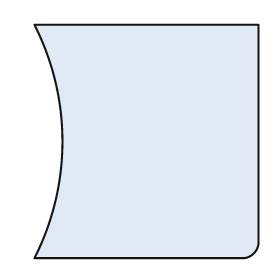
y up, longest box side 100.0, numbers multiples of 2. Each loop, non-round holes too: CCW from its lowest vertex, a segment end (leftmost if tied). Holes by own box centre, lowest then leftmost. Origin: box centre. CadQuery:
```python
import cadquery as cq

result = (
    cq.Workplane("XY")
    .moveTo(-48.0, -50.0)
    .lineTo(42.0, -50.0)
    .threePointArc((46.0, -48.0), (48.0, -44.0))
    .lineTo(48.0, 50.0)
    .lineTo(-48.0, 50.0)
    .threePointArc((-36.0, 0.0), (-48.0, -50.0))
    .close()
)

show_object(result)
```